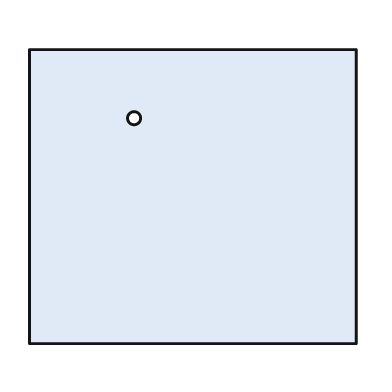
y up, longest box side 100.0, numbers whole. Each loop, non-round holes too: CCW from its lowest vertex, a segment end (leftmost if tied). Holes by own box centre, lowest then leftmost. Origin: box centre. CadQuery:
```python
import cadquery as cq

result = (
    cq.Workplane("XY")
    .moveTo(-50.0, -45.0)
    .lineTo(50.0, -45.0)
    .lineTo(50.0, 45.0)
    .lineTo(-50.0, 45.0)
    .close()
    .moveTo(-18.0, 24.0)
    .circle(2.0)
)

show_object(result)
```